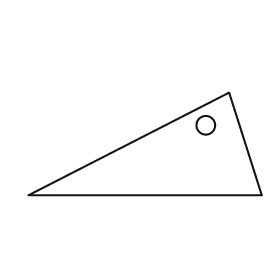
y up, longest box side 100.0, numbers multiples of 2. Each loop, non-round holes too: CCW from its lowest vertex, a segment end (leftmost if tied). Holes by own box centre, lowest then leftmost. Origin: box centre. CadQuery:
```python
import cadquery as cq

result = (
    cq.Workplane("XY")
    .moveTo(-50.0, -22.0)
    .lineTo(50.0, -22.0)
    .lineTo(36.0, 22.0)
    .close()
    .moveTo(26.0, 8.0)
    .circle(4.0)
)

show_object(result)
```